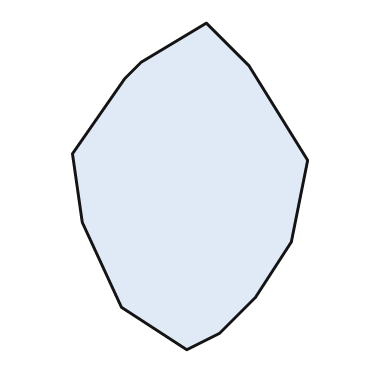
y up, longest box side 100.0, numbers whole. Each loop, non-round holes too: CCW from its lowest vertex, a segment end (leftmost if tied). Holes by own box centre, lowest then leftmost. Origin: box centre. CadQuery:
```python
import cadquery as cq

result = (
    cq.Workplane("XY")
    .moveTo(-1.0, -50.0)
    .lineTo(9.0, -45.0)
    .lineTo(20.0, -34.0)
    .lineTo(31.0, -17.0)
    .lineTo(36.0, 8.0)
    .lineTo(18.0, 37.0)
    .lineTo(5.0, 50.0)
    .lineTo(-15.0, 38.0)
    .lineTo(-20.0, 33.0)
    .lineTo(-36.0, 10.0)
    .lineTo(-33.0, -11.0)
    .lineTo(-21.0, -37.0)
    .close()
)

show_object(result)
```